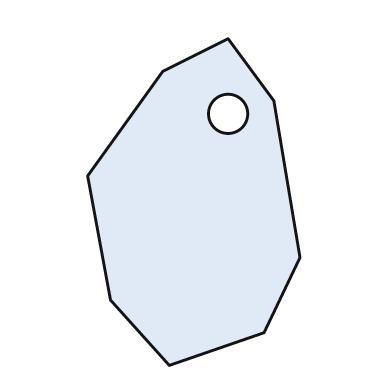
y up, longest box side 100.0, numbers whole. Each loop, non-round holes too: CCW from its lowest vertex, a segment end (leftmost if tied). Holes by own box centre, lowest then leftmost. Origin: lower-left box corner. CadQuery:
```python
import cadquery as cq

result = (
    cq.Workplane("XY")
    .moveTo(25.0, 0.0)
    .lineTo(54.0, 10.0)
    .lineTo(65.0, 33.0)
    .lineTo(57.0, 81.0)
    .lineTo(43.0, 100.0)
    .lineTo(23.0, 90.0)
    .lineTo(0.0, 58.0)
    .lineTo(7.0, 20.0)
    .close()
    .moveTo(43.0, 77.0)
    .circle(6.0)
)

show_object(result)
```